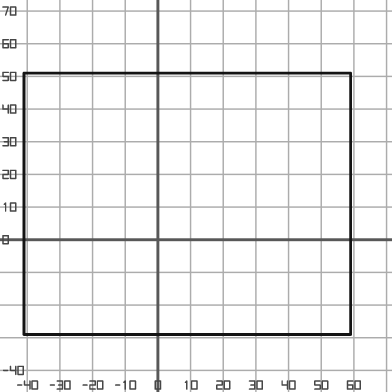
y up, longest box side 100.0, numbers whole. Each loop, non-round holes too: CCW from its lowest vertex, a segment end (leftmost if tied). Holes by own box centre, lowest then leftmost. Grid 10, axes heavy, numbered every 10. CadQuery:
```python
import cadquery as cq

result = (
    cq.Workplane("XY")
    .moveTo(-41.0, -29.0)
    .lineTo(59.0, -29.0)
    .lineTo(59.0, 51.0)
    .lineTo(-41.0, 51.0)
    .close()
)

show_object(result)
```